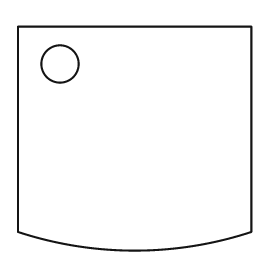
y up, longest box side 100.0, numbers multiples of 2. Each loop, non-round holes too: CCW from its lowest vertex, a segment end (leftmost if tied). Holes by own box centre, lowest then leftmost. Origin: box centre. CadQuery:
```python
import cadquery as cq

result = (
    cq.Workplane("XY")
    .moveTo(-50.0, -40.0)
    .threePointArc((0.0, -48.0), (50.0, -40.0))
    .lineTo(50.0, 48.0)
    .lineTo(-50.0, 48.0)
    .close()
    .moveTo(-32.0, 32.0)
    .circle(8.0)
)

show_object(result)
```